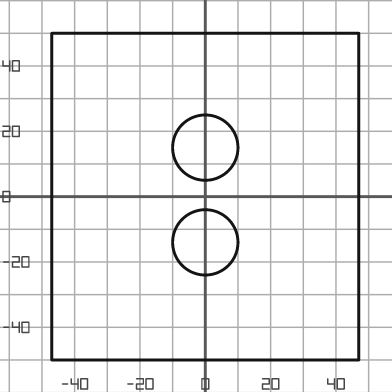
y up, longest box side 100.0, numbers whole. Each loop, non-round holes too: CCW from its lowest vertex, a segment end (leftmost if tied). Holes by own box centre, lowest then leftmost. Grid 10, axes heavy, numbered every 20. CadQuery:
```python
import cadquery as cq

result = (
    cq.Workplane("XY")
    .moveTo(-47.0, -50.0)
    .lineTo(47.0, -50.0)
    .lineTo(47.0, 50.0)
    .lineTo(-47.0, 50.0)
    .close()
    .moveTo(0.0, -14.0)
    .circle(10.0)
    .moveTo(0.0, 15.0)
    .circle(10.0)
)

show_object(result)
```